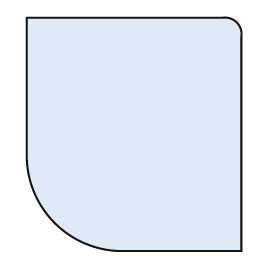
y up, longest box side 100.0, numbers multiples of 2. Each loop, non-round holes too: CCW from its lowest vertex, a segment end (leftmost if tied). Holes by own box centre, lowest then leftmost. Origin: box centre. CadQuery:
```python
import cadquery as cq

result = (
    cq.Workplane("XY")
    .moveTo(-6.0, -50.0)
    .lineTo(46.0, -50.0)
    .lineTo(46.0, 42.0)
    .threePointArc((44.0, 48.0), (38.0, 50.0))
    .lineTo(-46.0, 50.0)
    .lineTo(-46.0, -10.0)
    .threePointArc((-34.0, -38.0), (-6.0, -50.0))
    .close()
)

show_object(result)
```